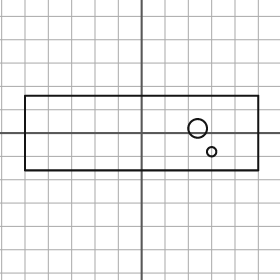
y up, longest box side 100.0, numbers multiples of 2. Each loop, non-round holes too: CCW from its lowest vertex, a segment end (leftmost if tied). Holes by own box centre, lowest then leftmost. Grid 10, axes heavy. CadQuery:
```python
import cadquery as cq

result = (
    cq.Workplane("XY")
    .moveTo(-50.0, -16.0)
    .lineTo(50.0, -16.0)
    .lineTo(50.0, 16.0)
    .lineTo(-50.0, 16.0)
    .close()
    .moveTo(30.0, -8.0)
    .circle(2.0)
    .moveTo(24.0, 2.0)
    .circle(4.0)
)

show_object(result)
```